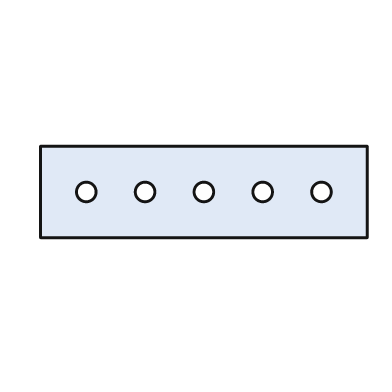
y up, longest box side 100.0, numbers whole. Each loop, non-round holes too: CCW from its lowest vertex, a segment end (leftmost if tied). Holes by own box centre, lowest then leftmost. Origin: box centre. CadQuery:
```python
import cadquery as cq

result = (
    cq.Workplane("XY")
    .moveTo(-50.0, -14.0)
    .lineTo(50.0, -14.0)
    .lineTo(50.0, 14.0)
    .lineTo(-50.0, 14.0)
    .close()
    .moveTo(-36.0, 0.0)
    .circle(3.0)
    .moveTo(-18.0, 0.0)
    .circle(3.0)
    .moveTo(0.0, 0.0)
    .circle(3.0)
    .moveTo(18.0, 0.0)
    .circle(3.0)
    .moveTo(36.0, 0.0)
    .circle(3.0)
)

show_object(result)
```